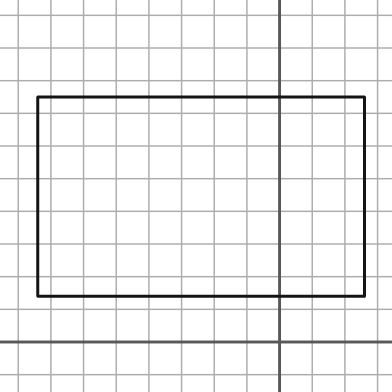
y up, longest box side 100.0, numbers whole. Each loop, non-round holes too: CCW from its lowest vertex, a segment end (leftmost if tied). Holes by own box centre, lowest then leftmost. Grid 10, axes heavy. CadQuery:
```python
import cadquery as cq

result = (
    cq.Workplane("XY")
    .moveTo(-74.0, 14.0)
    .lineTo(26.0, 14.0)
    .lineTo(26.0, 75.0)
    .lineTo(-74.0, 75.0)
    .close()
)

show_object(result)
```